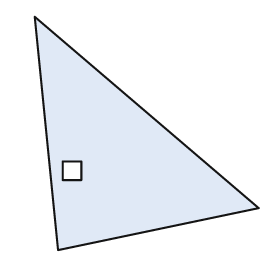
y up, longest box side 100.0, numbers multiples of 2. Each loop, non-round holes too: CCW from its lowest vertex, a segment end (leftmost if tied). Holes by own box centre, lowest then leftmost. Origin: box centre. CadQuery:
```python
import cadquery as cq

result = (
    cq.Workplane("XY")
    .moveTo(-38.0, -50.0)
    .lineTo(48.0, -32.0)
    .lineTo(-48.0, 50.0)
    .close()
    .moveTo(-36.0, -20.0)
    .lineTo(-28.0, -20.0)
    .lineTo(-28.0, -12.0)
    .lineTo(-36.0, -12.0)
    .close()
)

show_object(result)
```